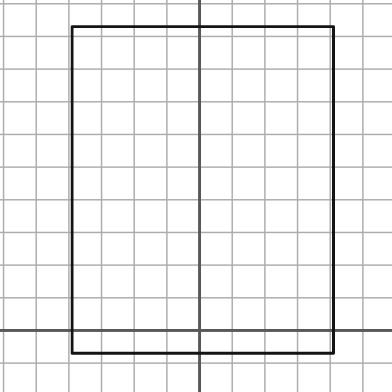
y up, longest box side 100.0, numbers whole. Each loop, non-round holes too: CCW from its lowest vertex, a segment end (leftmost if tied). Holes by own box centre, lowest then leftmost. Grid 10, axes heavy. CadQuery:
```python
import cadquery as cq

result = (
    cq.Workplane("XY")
    .moveTo(-39.0, -7.0)
    .lineTo(41.0, -7.0)
    .lineTo(41.0, 93.0)
    .lineTo(-39.0, 93.0)
    .close()
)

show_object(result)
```